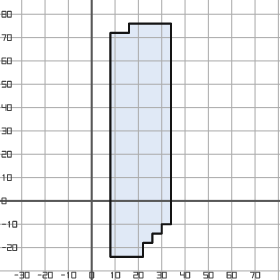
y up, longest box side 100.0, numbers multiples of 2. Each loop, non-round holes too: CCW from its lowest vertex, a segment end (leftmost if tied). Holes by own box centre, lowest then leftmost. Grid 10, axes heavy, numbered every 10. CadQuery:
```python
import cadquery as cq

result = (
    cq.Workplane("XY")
    .moveTo(8.0, -24.0)
    .lineTo(22.0, -24.0)
    .lineTo(22.0, -18.0)
    .lineTo(26.0, -18.0)
    .lineTo(26.0, -14.0)
    .lineTo(30.0, -14.0)
    .lineTo(30.0, -10.0)
    .lineTo(34.0, -10.0)
    .lineTo(34.0, 76.0)
    .lineTo(16.0, 76.0)
    .lineTo(16.0, 72.0)
    .lineTo(8.0, 72.0)
    .close()
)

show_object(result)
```